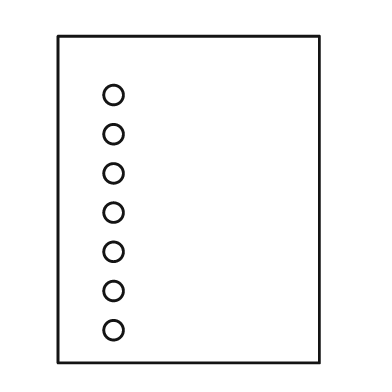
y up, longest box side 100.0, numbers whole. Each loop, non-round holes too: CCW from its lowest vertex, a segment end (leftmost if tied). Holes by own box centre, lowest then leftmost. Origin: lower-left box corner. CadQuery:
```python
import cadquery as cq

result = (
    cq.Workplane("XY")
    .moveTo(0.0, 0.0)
    .lineTo(80.0, 0.0)
    .lineTo(80.0, 100.0)
    .lineTo(0.0, 100.0)
    .close()
    .moveTo(17.0, 10.0)
    .circle(3.0)
    .moveTo(17.0, 22.0)
    .circle(3.0)
    .moveTo(17.0, 34.0)
    .circle(3.0)
    .moveTo(17.0, 46.0)
    .circle(3.0)
    .moveTo(17.0, 58.0)
    .circle(3.0)
    .moveTo(17.0, 70.0)
    .circle(3.0)
    .moveTo(17.0, 82.0)
    .circle(3.0)
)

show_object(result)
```